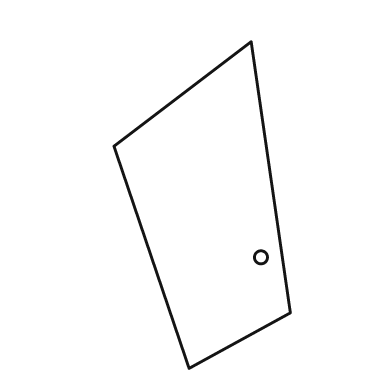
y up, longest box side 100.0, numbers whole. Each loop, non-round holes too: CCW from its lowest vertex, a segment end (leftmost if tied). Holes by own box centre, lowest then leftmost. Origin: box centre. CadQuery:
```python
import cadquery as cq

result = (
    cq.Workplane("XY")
    .moveTo(-4.0, -50.0)
    .lineTo(27.0, -33.0)
    .lineTo(15.0, 50.0)
    .lineTo(-27.0, 18.0)
    .close()
    .moveTo(18.0, -16.0)
    .circle(2.0)
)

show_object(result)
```